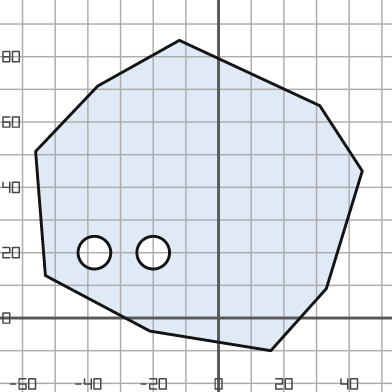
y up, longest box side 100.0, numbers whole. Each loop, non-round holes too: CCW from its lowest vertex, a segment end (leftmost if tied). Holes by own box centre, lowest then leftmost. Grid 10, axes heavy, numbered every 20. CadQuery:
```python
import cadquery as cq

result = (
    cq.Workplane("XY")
    .moveTo(16.0, -10.0)
    .lineTo(33.0, 9.0)
    .lineTo(44.0, 45.0)
    .lineTo(31.0, 65.0)
    .lineTo(-12.0, 85.0)
    .lineTo(-37.0, 71.0)
    .lineTo(-56.0, 51.0)
    .lineTo(-53.0, 13.0)
    .lineTo(-21.0, -4.0)
    .close()
    .moveTo(-38.0, 20.0)
    .circle(5.0)
    .moveTo(-20.0, 20.0)
    .circle(5.0)
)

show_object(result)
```